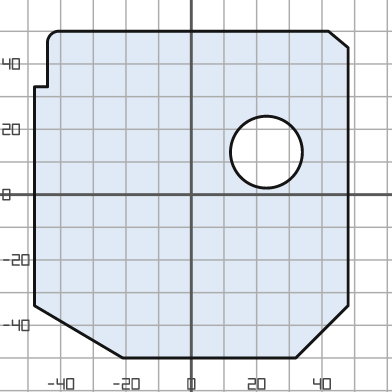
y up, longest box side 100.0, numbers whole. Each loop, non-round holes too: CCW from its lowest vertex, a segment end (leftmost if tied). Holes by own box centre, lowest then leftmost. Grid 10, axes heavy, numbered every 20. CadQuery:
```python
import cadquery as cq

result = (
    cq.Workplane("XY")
    .moveTo(-21.0, -50.0)
    .lineTo(32.0, -50.0)
    .lineTo(48.0, -34.0)
    .lineTo(48.0, 45.0)
    .lineTo(42.0, 50.0)
    .lineTo(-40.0, 50.0)
    .threePointArc((-43.0, 49.0), (-44.0, 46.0))
    .lineTo(-44.0, 33.0)
    .lineTo(-48.0, 33.0)
    .lineTo(-48.0, -34.0)
    .close()
    .moveTo(23.0, 13.0)
    .circle(11.0)
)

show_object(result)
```